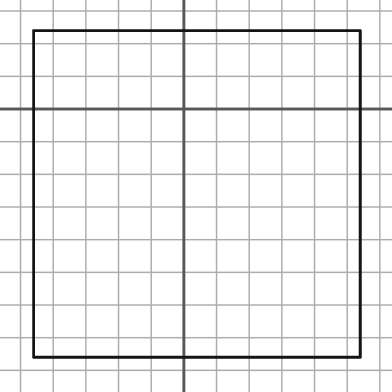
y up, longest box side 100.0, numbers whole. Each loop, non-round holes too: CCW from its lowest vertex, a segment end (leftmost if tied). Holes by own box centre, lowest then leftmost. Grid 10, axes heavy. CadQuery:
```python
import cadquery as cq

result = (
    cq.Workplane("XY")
    .moveTo(-46.0, -76.0)
    .lineTo(54.0, -76.0)
    .lineTo(54.0, 24.0)
    .lineTo(-46.0, 24.0)
    .close()
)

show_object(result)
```